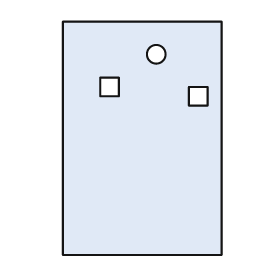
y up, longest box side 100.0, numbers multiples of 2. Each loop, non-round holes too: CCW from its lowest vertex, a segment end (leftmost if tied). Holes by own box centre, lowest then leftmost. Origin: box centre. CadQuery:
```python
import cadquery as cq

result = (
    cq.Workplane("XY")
    .moveTo(-34.0, -50.0)
    .lineTo(34.0, -50.0)
    .lineTo(34.0, 50.0)
    .lineTo(-34.0, 50.0)
    .close()
    .moveTo(20.0, 14.0)
    .lineTo(28.0, 14.0)
    .lineTo(28.0, 22.0)
    .lineTo(20.0, 22.0)
    .close()
    .moveTo(-18.0, 18.0)
    .lineTo(-10.0, 18.0)
    .lineTo(-10.0, 26.0)
    .lineTo(-18.0, 26.0)
    .close()
    .moveTo(6.0, 36.0)
    .circle(4.0)
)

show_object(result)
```